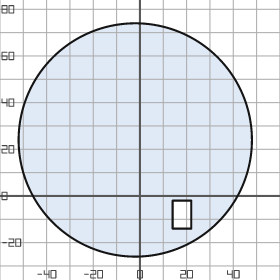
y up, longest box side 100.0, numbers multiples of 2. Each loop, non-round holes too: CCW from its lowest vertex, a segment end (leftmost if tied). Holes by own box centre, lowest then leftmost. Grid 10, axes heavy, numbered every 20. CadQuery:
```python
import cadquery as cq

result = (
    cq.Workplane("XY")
    .moveTo(-2.0, 24.0)
    .circle(50.0)
    .moveTo(14.0, -14.0)
    .lineTo(22.0, -14.0)
    .lineTo(22.0, -2.0)
    .lineTo(14.0, -2.0)
    .close()
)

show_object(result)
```